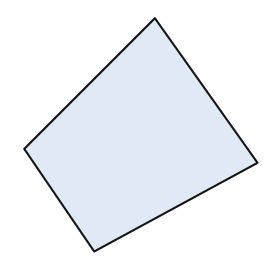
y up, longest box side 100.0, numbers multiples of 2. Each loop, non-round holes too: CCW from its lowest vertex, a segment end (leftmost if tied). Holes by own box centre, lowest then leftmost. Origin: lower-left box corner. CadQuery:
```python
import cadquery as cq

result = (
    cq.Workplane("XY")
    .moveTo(30.0, 0.0)
    .lineTo(100.0, 38.0)
    .lineTo(56.0, 100.0)
    .lineTo(0.0, 44.0)
    .close()
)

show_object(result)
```